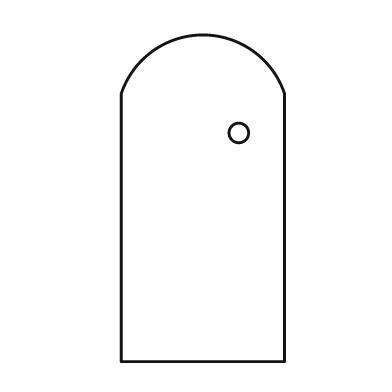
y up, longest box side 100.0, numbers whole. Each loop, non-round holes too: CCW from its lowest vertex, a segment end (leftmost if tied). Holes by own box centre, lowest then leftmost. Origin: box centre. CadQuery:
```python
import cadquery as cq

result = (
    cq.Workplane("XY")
    .moveTo(-25.0, -50.0)
    .lineTo(25.0, -50.0)
    .lineTo(25.0, 32.0)
    .threePointArc((0.0, 50.0), (-25.0, 32.0))
    .close()
    .moveTo(11.0, 20.0)
    .circle(3.0)
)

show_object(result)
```